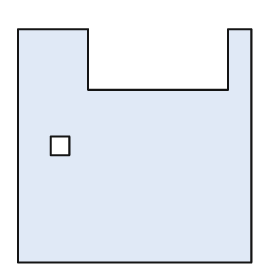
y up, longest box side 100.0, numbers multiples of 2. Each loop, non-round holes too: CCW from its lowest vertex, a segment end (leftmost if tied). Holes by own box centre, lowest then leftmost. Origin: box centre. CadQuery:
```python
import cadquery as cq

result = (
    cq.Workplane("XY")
    .moveTo(-50.0, -50.0)
    .lineTo(50.0, -50.0)
    .lineTo(50.0, 50.0)
    .lineTo(40.0, 50.0)
    .lineTo(40.0, 24.0)
    .lineTo(-20.0, 24.0)
    .lineTo(-20.0, 50.0)
    .lineTo(-50.0, 50.0)
    .close()
    .moveTo(-36.0, -4.0)
    .lineTo(-28.0, -4.0)
    .lineTo(-28.0, 4.0)
    .lineTo(-36.0, 4.0)
    .close()
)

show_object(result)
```